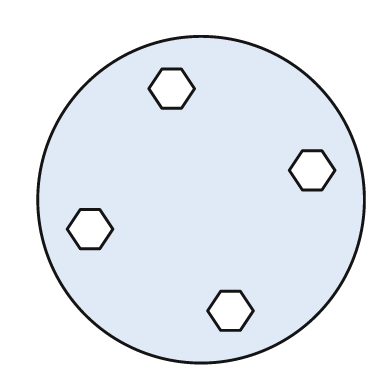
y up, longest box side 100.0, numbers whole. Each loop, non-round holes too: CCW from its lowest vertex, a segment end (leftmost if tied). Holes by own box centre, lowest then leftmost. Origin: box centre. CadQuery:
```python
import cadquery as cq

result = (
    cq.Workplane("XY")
    .moveTo(0.0, 0.0)
    .circle(50.0)
    .moveTo(6.0, -40.0)
    .lineTo(12.0, -40.0)
    .lineTo(16.0, -34.0)
    .lineTo(12.0, -28.0)
    .lineTo(6.0, -28.0)
    .lineTo(2.0, -34.0)
    .close()
    .moveTo(-37.0, -15.0)
    .lineTo(-31.0, -15.0)
    .lineTo(-27.0, -9.0)
    .lineTo(-31.0, -3.0)
    .lineTo(-37.0, -3.0)
    .lineTo(-41.0, -9.0)
    .close()
    .moveTo(31.0, 3.0)
    .lineTo(37.0, 3.0)
    .lineTo(41.0, 9.0)
    .lineTo(37.0, 15.0)
    .lineTo(31.0, 15.0)
    .lineTo(27.0, 9.0)
    .close()
    .moveTo(-12.0, 28.0)
    .lineTo(-6.0, 28.0)
    .lineTo(-2.0, 34.0)
    .lineTo(-6.0, 40.0)
    .lineTo(-12.0, 40.0)
    .lineTo(-16.0, 34.0)
    .close()
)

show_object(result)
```